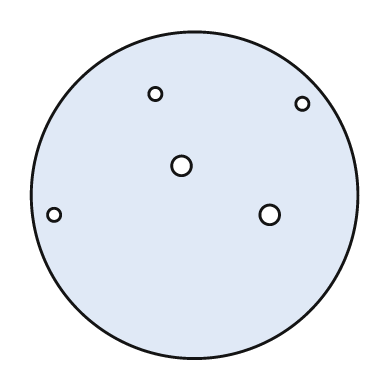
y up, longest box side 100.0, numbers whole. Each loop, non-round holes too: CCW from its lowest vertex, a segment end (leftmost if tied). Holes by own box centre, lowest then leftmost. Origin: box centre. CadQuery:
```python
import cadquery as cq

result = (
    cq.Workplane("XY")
    .moveTo(0.0, 0.0)
    .circle(50.0)
    .moveTo(-43.0, -6.0)
    .circle(2.0)
    .moveTo(23.0, -6.0)
    .circle(3.0)
    .moveTo(-4.0, 9.0)
    .circle(3.0)
    .moveTo(33.0, 28.0)
    .circle(2.0)
    .moveTo(-12.0, 31.0)
    .circle(2.0)
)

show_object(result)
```